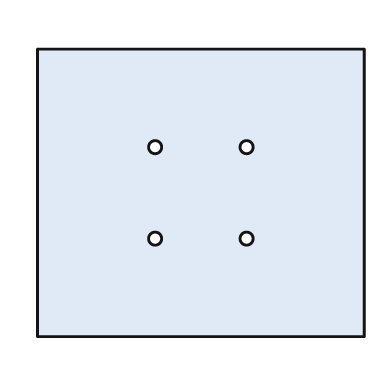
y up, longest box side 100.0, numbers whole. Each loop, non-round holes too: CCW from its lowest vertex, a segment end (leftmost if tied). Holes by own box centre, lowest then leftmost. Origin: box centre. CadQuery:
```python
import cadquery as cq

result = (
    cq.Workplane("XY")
    .moveTo(-50.0, -44.0)
    .lineTo(50.0, -44.0)
    .lineTo(50.0, 44.0)
    .lineTo(-50.0, 44.0)
    .close()
    .moveTo(-14.0, -14.0)
    .circle(2.0)
    .moveTo(14.0, -14.0)
    .circle(2.0)
    .moveTo(-14.0, 14.0)
    .circle(2.0)
    .moveTo(14.0, 14.0)
    .circle(2.0)
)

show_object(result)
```